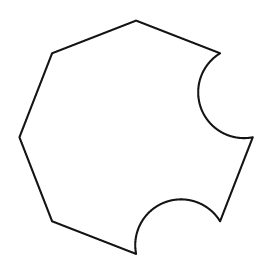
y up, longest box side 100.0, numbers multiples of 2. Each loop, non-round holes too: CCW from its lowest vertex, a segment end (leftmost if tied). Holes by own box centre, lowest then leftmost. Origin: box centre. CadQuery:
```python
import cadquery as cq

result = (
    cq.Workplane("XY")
    .moveTo(0.0, -50.0)
    .threePointArc((12.0, -28.0), (36.0, -36.0))
    .lineTo(50.0, 0.0)
    .threePointArc((28.0, 12.0), (36.0, 36.0))
    .lineTo(0.0, 50.0)
    .lineTo(-36.0, 36.0)
    .lineTo(-50.0, 0.0)
    .lineTo(-36.0, -36.0)
    .close()
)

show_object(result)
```